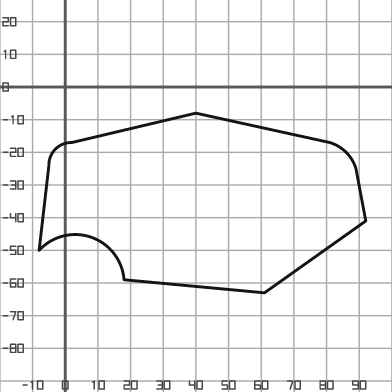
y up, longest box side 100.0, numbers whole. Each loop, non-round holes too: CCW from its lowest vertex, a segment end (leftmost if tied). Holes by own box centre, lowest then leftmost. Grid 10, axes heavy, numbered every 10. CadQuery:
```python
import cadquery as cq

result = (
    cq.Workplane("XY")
    .moveTo(61.0, -63.0)
    .lineTo(92.0, -41.0)
    .lineTo(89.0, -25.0)
    .threePointArc((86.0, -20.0), (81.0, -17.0))
    .lineTo(40.0, -8.0)
    .lineTo(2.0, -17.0)
    .threePointArc((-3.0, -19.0), (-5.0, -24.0))
    .lineTo(-8.0, -50.0)
    .threePointArc((8.0, -46.0), (18.0, -59.0))
    .close()
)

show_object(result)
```